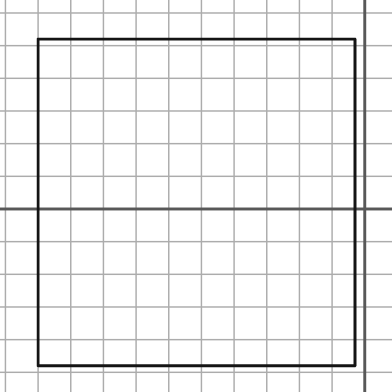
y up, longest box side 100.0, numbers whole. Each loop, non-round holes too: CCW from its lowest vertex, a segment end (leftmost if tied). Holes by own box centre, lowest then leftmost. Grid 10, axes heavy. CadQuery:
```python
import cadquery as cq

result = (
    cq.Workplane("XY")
    .moveTo(-100.0, -48.0)
    .lineTo(-3.0, -48.0)
    .lineTo(-3.0, 52.0)
    .lineTo(-100.0, 52.0)
    .close()
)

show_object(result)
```